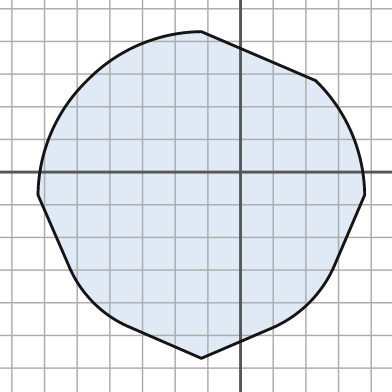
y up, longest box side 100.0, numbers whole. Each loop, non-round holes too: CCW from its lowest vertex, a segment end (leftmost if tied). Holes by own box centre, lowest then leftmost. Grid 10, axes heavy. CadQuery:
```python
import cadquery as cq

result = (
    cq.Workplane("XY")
    .moveTo(-12.0, -57.0)
    .lineTo(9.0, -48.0)
    .threePointArc((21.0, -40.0), (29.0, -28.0))
    .lineTo(38.0, -7.0)
    .threePointArc((34.0, 12.0), (23.0, 28.0))
    .lineTo(-12.0, 43.0)
    .threePointArc((-31.0, 39.0), (-47.0, 28.0))
    .threePointArc((-58.0, 12.0), (-62.0, -7.0))
    .lineTo(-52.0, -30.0)
    .threePointArc((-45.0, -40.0), (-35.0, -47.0))
    .close()
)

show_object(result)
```